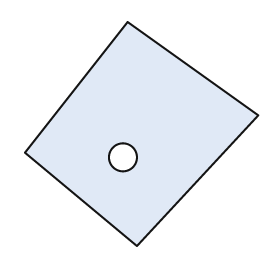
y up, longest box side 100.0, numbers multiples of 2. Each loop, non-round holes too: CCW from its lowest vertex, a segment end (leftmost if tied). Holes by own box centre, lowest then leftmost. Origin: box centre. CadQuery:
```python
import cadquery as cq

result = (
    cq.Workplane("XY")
    .moveTo(-2.0, -48.0)
    .lineTo(50.0, 8.0)
    .lineTo(-6.0, 48.0)
    .lineTo(-50.0, -8.0)
    .close()
    .moveTo(-8.0, -10.0)
    .circle(6.0)
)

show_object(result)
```